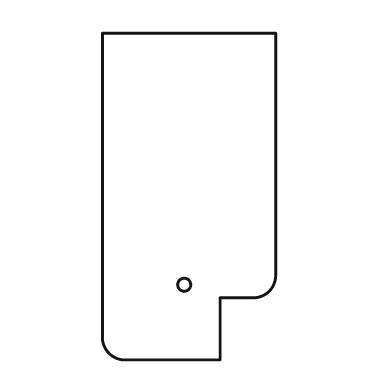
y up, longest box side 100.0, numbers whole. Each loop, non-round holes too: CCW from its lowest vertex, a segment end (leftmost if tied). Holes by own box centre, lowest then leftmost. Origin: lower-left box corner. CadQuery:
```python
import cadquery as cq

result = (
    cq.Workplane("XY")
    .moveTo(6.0, 0.0)
    .lineTo(36.0, 0.0)
    .lineTo(36.0, 19.0)
    .lineTo(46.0, 19.0)
    .threePointArc((51.0, 21.0), (53.0, 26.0))
    .lineTo(53.0, 100.0)
    .lineTo(0.0, 100.0)
    .lineTo(0.0, 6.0)
    .threePointArc((2.0, 2.0), (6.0, 0.0))
    .close()
    .moveTo(25.0, 23.0)
    .circle(2.0)
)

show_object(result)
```